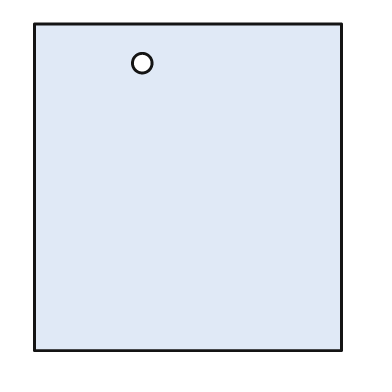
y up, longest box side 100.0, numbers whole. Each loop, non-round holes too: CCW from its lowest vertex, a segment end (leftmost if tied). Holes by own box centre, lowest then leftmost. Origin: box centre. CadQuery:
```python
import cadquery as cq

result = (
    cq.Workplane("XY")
    .moveTo(-47.0, -50.0)
    .lineTo(47.0, -50.0)
    .lineTo(47.0, 50.0)
    .lineTo(-47.0, 50.0)
    .close()
    .moveTo(-14.0, 38.0)
    .circle(3.0)
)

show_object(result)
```